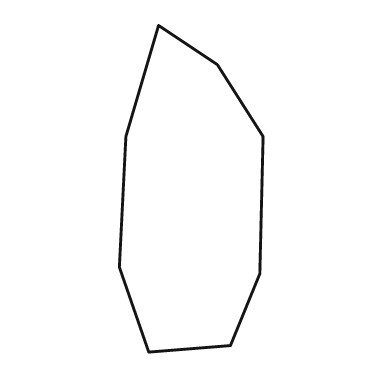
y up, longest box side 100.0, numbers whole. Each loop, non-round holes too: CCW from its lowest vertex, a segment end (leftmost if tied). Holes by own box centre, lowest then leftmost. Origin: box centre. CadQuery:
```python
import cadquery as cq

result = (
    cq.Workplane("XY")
    .moveTo(-13.0, -50.0)
    .lineTo(12.0, -48.0)
    .lineTo(21.0, -26.0)
    .lineTo(22.0, 16.0)
    .lineTo(8.0, 38.0)
    .lineTo(-10.0, 50.0)
    .lineTo(-20.0, 16.0)
    .lineTo(-22.0, -24.0)
    .close()
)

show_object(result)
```